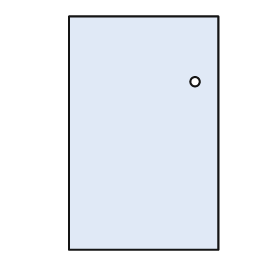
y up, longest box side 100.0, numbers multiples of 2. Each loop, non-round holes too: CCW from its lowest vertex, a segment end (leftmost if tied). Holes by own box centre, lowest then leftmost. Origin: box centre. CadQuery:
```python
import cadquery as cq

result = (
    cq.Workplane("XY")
    .moveTo(-32.0, -50.0)
    .lineTo(32.0, -50.0)
    .lineTo(32.0, 50.0)
    .lineTo(-32.0, 50.0)
    .close()
    .moveTo(22.0, 22.0)
    .circle(2.0)
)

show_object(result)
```